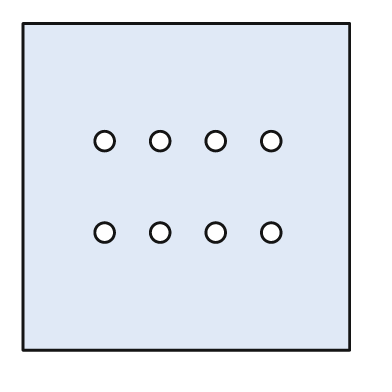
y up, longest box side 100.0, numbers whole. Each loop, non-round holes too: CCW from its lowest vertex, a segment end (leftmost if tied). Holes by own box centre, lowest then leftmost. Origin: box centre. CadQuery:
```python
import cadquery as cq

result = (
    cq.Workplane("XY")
    .moveTo(-50.0, -50.0)
    .lineTo(50.0, -50.0)
    .lineTo(50.0, 50.0)
    .lineTo(-50.0, 50.0)
    .close()
    .moveTo(-25.0, -14.0)
    .circle(3.0)
    .moveTo(-8.0, -14.0)
    .circle(3.0)
    .moveTo(9.0, -14.0)
    .circle(3.0)
    .moveTo(26.0, -14.0)
    .circle(3.0)
    .moveTo(-25.0, 14.0)
    .circle(3.0)
    .moveTo(-8.0, 14.0)
    .circle(3.0)
    .moveTo(9.0, 14.0)
    .circle(3.0)
    .moveTo(26.0, 14.0)
    .circle(3.0)
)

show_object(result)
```